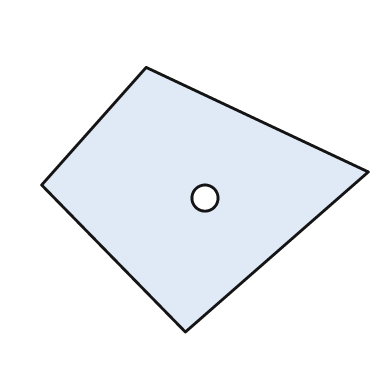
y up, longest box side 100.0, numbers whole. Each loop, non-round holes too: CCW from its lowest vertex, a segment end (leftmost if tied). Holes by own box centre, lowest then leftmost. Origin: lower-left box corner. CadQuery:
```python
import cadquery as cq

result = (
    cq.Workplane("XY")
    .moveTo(44.0, 0.0)
    .lineTo(100.0, 49.0)
    .lineTo(32.0, 81.0)
    .lineTo(0.0, 45.0)
    .close()
    .moveTo(50.0, 41.0)
    .circle(4.0)
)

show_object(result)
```